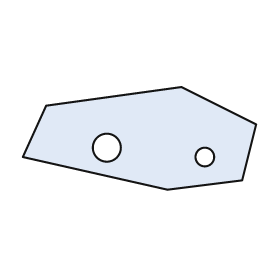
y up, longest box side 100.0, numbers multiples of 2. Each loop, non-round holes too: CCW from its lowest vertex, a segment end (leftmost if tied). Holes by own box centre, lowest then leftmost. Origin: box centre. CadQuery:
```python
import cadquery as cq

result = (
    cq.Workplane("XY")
    .moveTo(12.0, -22.0)
    .lineTo(44.0, -18.0)
    .lineTo(50.0, 6.0)
    .lineTo(18.0, 22.0)
    .lineTo(-40.0, 14.0)
    .lineTo(-50.0, -8.0)
    .close()
    .moveTo(28.0, -8.0)
    .circle(4.0)
    .moveTo(-14.0, -4.0)
    .circle(6.0)
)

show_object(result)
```